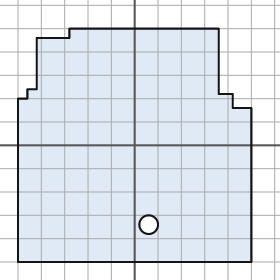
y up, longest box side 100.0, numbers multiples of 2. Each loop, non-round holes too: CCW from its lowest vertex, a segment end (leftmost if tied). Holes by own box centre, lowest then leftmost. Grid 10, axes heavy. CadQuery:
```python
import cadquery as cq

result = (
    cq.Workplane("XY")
    .moveTo(-50.0, -50.0)
    .lineTo(50.0, -50.0)
    .lineTo(50.0, 16.0)
    .lineTo(42.0, 16.0)
    .lineTo(42.0, 22.0)
    .lineTo(36.0, 22.0)
    .lineTo(36.0, 50.0)
    .lineTo(-28.0, 50.0)
    .lineTo(-28.0, 46.0)
    .lineTo(-42.0, 46.0)
    .lineTo(-42.0, 24.0)
    .lineTo(-46.0, 24.0)
    .lineTo(-46.0, 20.0)
    .lineTo(-50.0, 20.0)
    .close()
    .moveTo(6.0, -34.0)
    .circle(4.0)
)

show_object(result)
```